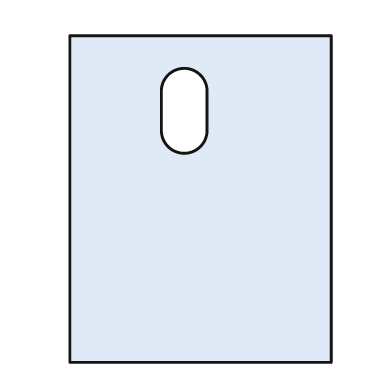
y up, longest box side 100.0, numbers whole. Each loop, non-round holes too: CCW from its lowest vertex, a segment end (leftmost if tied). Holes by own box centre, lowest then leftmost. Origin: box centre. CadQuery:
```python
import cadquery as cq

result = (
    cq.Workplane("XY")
    .moveTo(-40.0, -50.0)
    .lineTo(40.0, -50.0)
    .lineTo(40.0, 50.0)
    .lineTo(-40.0, 50.0)
    .close()
    .moveTo(-12.0, 21.0)
    .threePointArc((-5.0, 14.0), (2.0, 21.0))
    .lineTo(2.0, 33.0)
    .threePointArc((-5.0, 40.0), (-12.0, 33.0))
    .close()
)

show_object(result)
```